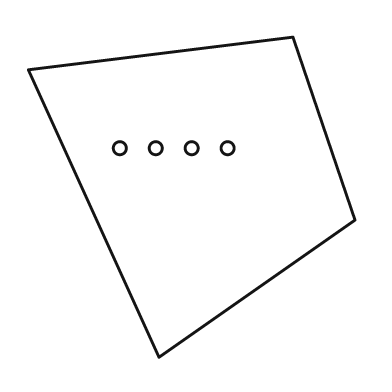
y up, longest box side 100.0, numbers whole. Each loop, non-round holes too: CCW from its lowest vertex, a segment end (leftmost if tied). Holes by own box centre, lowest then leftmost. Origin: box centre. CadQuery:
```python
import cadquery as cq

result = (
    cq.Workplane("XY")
    .moveTo(-10.0, -49.0)
    .lineTo(50.0, -7.0)
    .lineTo(31.0, 49.0)
    .lineTo(-50.0, 39.0)
    .close()
    .moveTo(-22.0, 15.0)
    .circle(2.0)
    .moveTo(-11.0, 15.0)
    .circle(2.0)
    .moveTo(0.0, 15.0)
    .circle(2.0)
    .moveTo(11.0, 15.0)
    .circle(2.0)
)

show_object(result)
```